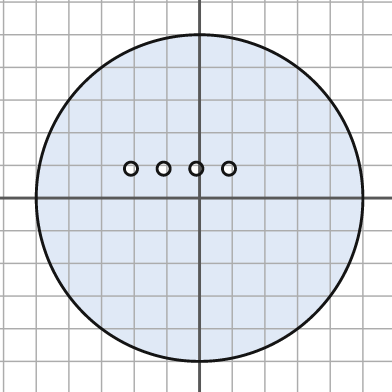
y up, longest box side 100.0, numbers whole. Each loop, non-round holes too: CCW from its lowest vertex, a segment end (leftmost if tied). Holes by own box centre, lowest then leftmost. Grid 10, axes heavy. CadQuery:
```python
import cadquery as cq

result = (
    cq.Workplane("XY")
    .moveTo(0.0, 0.0)
    .circle(50.0)
    .moveTo(-21.0, 9.0)
    .circle(2.0)
    .moveTo(-11.0, 9.0)
    .circle(2.0)
    .moveTo(-1.0, 9.0)
    .circle(2.0)
    .moveTo(9.0, 9.0)
    .circle(2.0)
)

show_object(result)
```